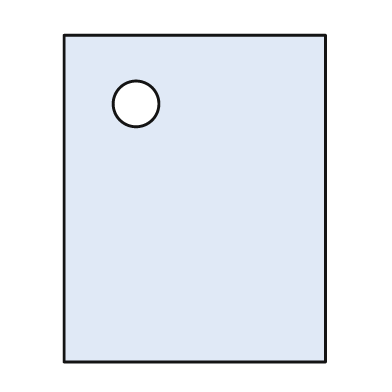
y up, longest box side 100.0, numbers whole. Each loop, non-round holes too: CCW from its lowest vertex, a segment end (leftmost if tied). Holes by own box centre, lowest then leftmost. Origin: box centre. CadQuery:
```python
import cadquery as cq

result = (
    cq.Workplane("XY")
    .moveTo(-40.0, -50.0)
    .lineTo(40.0, -50.0)
    .lineTo(40.0, 50.0)
    .lineTo(-40.0, 50.0)
    .close()
    .moveTo(-18.0, 29.0)
    .circle(7.0)
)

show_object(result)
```